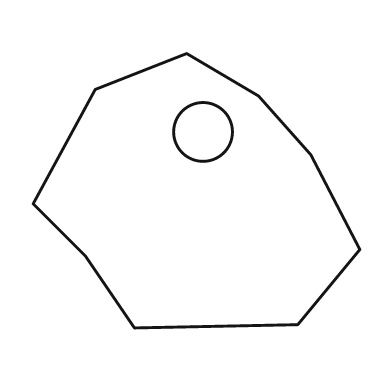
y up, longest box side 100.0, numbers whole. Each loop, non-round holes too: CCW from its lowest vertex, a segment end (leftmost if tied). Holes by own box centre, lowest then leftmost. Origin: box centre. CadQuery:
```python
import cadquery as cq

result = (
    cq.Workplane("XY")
    .moveTo(-19.0, -42.0)
    .lineTo(31.0, -41.0)
    .lineTo(50.0, -18.0)
    .lineTo(35.0, 11.0)
    .lineTo(19.0, 29.0)
    .lineTo(-3.0, 42.0)
    .lineTo(-31.0, 31.0)
    .lineTo(-50.0, -4.0)
    .lineTo(-34.0, -20.0)
    .close()
    .moveTo(2.0, 18.0)
    .circle(9.0)
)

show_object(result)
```